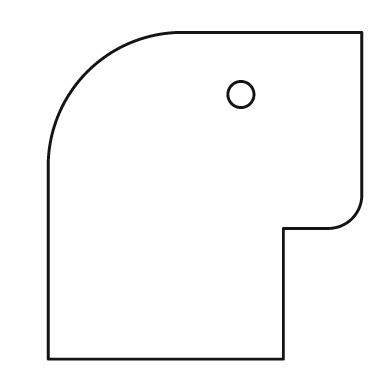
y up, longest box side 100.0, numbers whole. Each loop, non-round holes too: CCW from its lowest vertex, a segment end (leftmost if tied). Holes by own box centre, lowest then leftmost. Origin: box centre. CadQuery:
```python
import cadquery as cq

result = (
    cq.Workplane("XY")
    .moveTo(-48.0, -50.0)
    .lineTo(24.0, -50.0)
    .lineTo(24.0, -10.0)
    .lineTo(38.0, -10.0)
    .threePointArc((45.0, -7.0), (48.0, 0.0))
    .lineTo(48.0, 50.0)
    .lineTo(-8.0, 50.0)
    .threePointArc((-36.0, 38.0), (-48.0, 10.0))
    .close()
    .moveTo(11.0, 31.0)
    .circle(4.0)
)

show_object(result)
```